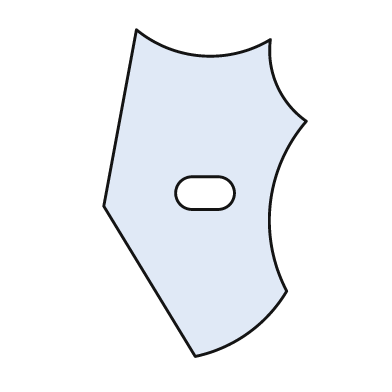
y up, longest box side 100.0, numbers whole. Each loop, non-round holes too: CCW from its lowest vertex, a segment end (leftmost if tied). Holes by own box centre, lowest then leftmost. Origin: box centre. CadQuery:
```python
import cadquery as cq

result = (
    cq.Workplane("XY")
    .moveTo(-3.0, -50.0)
    .threePointArc((13.0, -43.0), (25.0, -30.0))
    .threePointArc((20.0, -3.0), (31.0, 22.0))
    .threePointArc((22.0, 33.0), (20.0, 47.0))
    .threePointArc((-1.0, 42.0), (-21.0, 50.0))
    .lineTo(-31.0, -4.0)
    .close()
    .moveTo(-4.0, -5.0)
    .lineTo(4.0, -5.0)
    .threePointArc((9.0, 0.0), (4.0, 5.0))
    .lineTo(-4.0, 5.0)
    .threePointArc((-9.0, 0.0), (-4.0, -5.0))
    .close()
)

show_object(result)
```